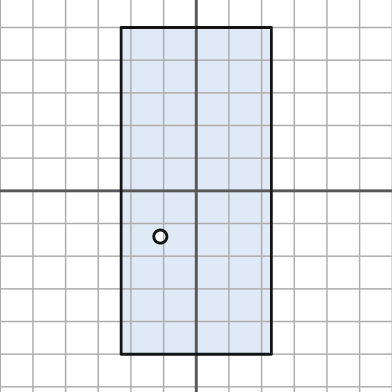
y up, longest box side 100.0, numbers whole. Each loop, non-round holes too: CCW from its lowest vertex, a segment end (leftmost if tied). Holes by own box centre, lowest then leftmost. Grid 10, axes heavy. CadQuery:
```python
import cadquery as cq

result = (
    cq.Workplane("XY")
    .moveTo(-23.0, -50.0)
    .lineTo(23.0, -50.0)
    .lineTo(23.0, 50.0)
    .lineTo(-23.0, 50.0)
    .close()
    .moveTo(-11.0, -14.0)
    .circle(2.0)
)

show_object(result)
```